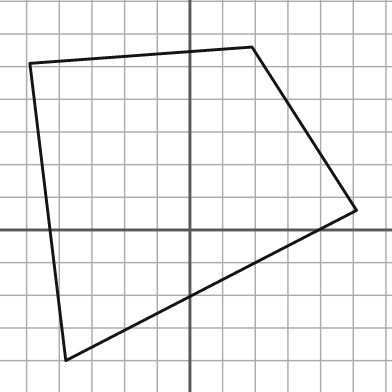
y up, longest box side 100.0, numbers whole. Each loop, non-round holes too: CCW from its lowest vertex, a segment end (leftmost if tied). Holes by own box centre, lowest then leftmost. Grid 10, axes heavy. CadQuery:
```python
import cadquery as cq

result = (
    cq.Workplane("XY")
    .moveTo(-38.0, -40.0)
    .lineTo(51.0, 6.0)
    .lineTo(19.0, 56.0)
    .lineTo(-49.0, 51.0)
    .close()
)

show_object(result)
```